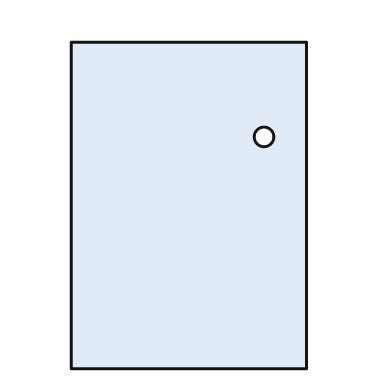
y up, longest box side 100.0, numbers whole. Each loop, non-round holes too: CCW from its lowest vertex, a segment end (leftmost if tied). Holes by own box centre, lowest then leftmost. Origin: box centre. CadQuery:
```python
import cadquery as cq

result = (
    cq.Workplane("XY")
    .moveTo(-36.0, -50.0)
    .lineTo(36.0, -50.0)
    .lineTo(36.0, 50.0)
    .lineTo(-36.0, 50.0)
    .close()
    .moveTo(23.0, 21.0)
    .circle(3.0)
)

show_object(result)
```